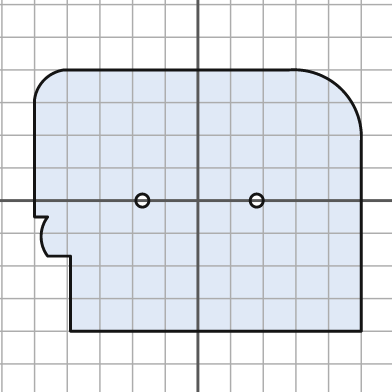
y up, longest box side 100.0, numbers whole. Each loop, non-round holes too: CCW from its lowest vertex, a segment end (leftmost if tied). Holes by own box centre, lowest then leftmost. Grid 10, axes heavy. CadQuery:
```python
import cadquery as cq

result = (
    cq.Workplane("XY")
    .moveTo(-39.0, -40.0)
    .lineTo(50.0, -40.0)
    .lineTo(50.0, 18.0)
    .threePointArc((44.0, 34.0), (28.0, 40.0))
    .lineTo(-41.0, 40.0)
    .threePointArc((-47.0, 37.0), (-50.0, 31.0))
    .lineTo(-50.0, -5.0)
    .lineTo(-46.0, -5.0)
    .threePointArc((-48.0, -11.0), (-46.0, -17.0))
    .lineTo(-39.0, -17.0)
    .close()
    .moveTo(-17.0, 0.0)
    .circle(2.0)
    .moveTo(18.0, 0.0)
    .circle(2.0)
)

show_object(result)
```